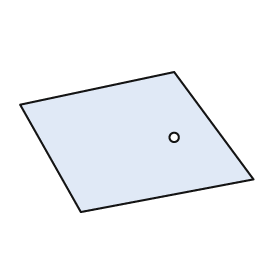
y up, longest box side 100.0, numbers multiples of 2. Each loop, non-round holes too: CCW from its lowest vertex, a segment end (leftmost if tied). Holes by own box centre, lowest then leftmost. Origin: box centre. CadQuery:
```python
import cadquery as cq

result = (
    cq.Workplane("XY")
    .moveTo(-24.0, -30.0)
    .lineTo(50.0, -16.0)
    .lineTo(16.0, 30.0)
    .lineTo(-50.0, 16.0)
    .close()
    .moveTo(16.0, 2.0)
    .circle(2.0)
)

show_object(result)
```